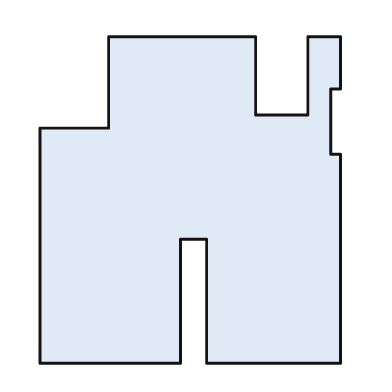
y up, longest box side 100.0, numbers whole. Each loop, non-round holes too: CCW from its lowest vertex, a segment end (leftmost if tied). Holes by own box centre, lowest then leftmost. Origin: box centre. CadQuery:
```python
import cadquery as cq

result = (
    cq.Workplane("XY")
    .moveTo(-46.0, -50.0)
    .lineTo(-3.0, -50.0)
    .lineTo(-3.0, -12.0)
    .lineTo(5.0, -12.0)
    .lineTo(5.0, -50.0)
    .lineTo(46.0, -50.0)
    .lineTo(46.0, 14.0)
    .lineTo(43.0, 14.0)
    .lineTo(43.0, 34.0)
    .lineTo(46.0, 34.0)
    .lineTo(46.0, 50.0)
    .lineTo(36.0, 50.0)
    .lineTo(36.0, 26.0)
    .lineTo(20.0, 26.0)
    .lineTo(20.0, 50.0)
    .lineTo(-25.0, 50.0)
    .lineTo(-25.0, 22.0)
    .lineTo(-46.0, 22.0)
    .close()
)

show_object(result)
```